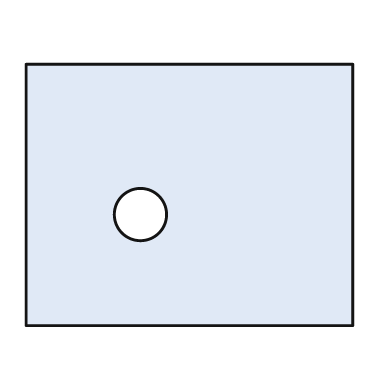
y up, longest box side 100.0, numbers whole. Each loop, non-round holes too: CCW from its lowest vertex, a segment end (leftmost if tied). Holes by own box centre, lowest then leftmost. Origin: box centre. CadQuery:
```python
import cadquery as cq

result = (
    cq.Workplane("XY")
    .moveTo(-50.0, -40.0)
    .lineTo(50.0, -40.0)
    .lineTo(50.0, 40.0)
    .lineTo(-50.0, 40.0)
    .close()
    .moveTo(-15.0, -6.0)
    .circle(8.0)
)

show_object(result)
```